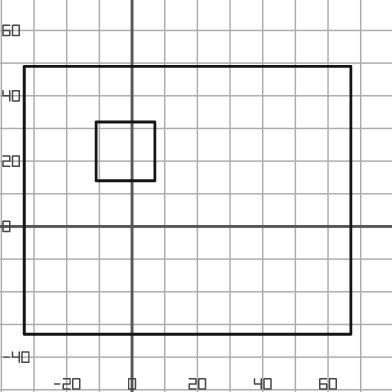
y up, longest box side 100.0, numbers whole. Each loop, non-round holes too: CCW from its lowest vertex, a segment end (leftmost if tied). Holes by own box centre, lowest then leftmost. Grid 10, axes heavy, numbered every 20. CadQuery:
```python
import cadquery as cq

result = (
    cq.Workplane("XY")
    .moveTo(-33.0, -33.0)
    .lineTo(67.0, -33.0)
    .lineTo(67.0, 49.0)
    .lineTo(-33.0, 49.0)
    .close()
    .moveTo(-11.0, 14.0)
    .lineTo(7.0, 14.0)
    .lineTo(7.0, 32.0)
    .lineTo(-11.0, 32.0)
    .close()
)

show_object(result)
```